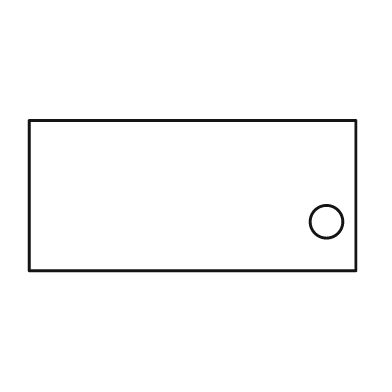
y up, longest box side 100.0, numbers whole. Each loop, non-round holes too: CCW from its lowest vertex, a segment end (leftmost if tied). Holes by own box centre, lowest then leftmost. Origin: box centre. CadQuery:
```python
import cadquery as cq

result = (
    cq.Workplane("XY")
    .moveTo(-50.0, -23.0)
    .lineTo(50.0, -23.0)
    .lineTo(50.0, 23.0)
    .lineTo(-50.0, 23.0)
    .close()
    .moveTo(41.0, -8.0)
    .circle(5.0)
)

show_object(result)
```